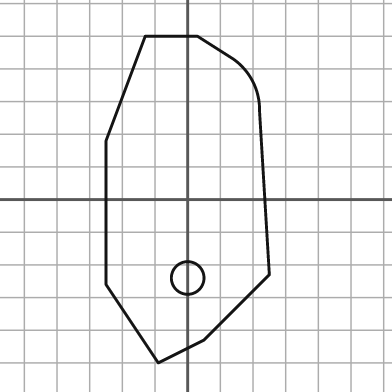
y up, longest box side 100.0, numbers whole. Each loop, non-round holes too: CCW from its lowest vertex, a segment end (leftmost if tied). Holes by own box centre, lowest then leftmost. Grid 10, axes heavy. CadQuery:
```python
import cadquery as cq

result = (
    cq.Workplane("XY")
    .moveTo(-9.0, -50.0)
    .lineTo(5.0, -43.0)
    .lineTo(25.0, -23.0)
    .lineTo(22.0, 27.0)
    .threePointArc((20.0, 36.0), (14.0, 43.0))
    .lineTo(3.0, 50.0)
    .lineTo(-13.0, 50.0)
    .lineTo(-25.0, 18.0)
    .lineTo(-25.0, -26.0)
    .close()
    .moveTo(0.0, -24.0)
    .circle(5.0)
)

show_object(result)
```